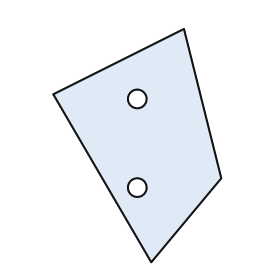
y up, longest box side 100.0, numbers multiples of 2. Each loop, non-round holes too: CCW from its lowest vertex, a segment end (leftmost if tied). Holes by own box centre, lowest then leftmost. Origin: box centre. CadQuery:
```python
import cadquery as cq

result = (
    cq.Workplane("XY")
    .moveTo(6.0, -50.0)
    .lineTo(36.0, -14.0)
    .lineTo(20.0, 50.0)
    .lineTo(-36.0, 22.0)
    .close()
    .moveTo(0.0, -18.0)
    .circle(4.0)
    .moveTo(0.0, 20.0)
    .circle(4.0)
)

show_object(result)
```